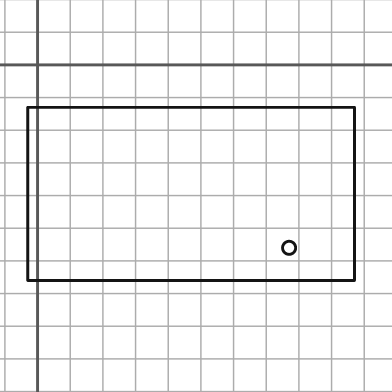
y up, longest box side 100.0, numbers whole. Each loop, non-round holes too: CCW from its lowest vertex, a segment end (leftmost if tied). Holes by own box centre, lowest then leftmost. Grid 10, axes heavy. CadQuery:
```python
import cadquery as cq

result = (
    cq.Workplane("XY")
    .moveTo(-3.0, -66.0)
    .lineTo(97.0, -66.0)
    .lineTo(97.0, -13.0)
    .lineTo(-3.0, -13.0)
    .close()
    .moveTo(77.0, -56.0)
    .circle(2.0)
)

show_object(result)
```